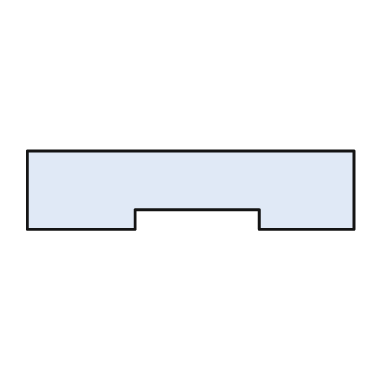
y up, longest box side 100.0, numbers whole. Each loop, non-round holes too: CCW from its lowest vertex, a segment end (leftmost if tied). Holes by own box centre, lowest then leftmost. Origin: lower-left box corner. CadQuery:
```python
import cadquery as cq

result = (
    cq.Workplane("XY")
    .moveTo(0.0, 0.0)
    .lineTo(33.0, 0.0)
    .lineTo(33.0, 6.0)
    .lineTo(71.0, 6.0)
    .lineTo(71.0, 0.0)
    .lineTo(100.0, 0.0)
    .lineTo(100.0, 24.0)
    .lineTo(0.0, 24.0)
    .close()
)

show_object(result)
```